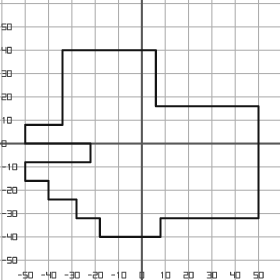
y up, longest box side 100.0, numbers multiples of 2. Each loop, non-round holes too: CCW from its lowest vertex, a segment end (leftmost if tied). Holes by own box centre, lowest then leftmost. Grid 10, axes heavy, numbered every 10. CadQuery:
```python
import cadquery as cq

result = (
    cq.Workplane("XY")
    .moveTo(-18.0, -40.0)
    .lineTo(8.0, -40.0)
    .lineTo(8.0, -32.0)
    .lineTo(50.0, -32.0)
    .lineTo(50.0, 16.0)
    .lineTo(6.0, 16.0)
    .lineTo(6.0, 40.0)
    .lineTo(-34.0, 40.0)
    .lineTo(-34.0, 8.0)
    .lineTo(-50.0, 8.0)
    .lineTo(-50.0, 0.0)
    .lineTo(-22.0, 0.0)
    .lineTo(-22.0, -8.0)
    .lineTo(-50.0, -8.0)
    .lineTo(-50.0, -16.0)
    .lineTo(-40.0, -16.0)
    .lineTo(-40.0, -24.0)
    .lineTo(-28.0, -24.0)
    .lineTo(-28.0, -32.0)
    .lineTo(-18.0, -32.0)
    .close()
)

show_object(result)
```